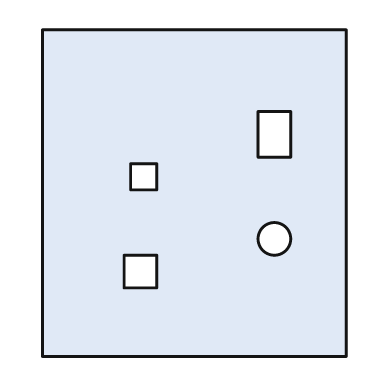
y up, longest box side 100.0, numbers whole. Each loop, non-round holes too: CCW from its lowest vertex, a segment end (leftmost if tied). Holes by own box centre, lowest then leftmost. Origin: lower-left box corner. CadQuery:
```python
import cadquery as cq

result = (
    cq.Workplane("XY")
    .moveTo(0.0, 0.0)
    .lineTo(93.0, 0.0)
    .lineTo(93.0, 100.0)
    .lineTo(0.0, 100.0)
    .close()
    .moveTo(25.0, 21.0)
    .lineTo(35.0, 21.0)
    .lineTo(35.0, 31.0)
    .lineTo(25.0, 31.0)
    .close()
    .moveTo(71.0, 36.0)
    .circle(5.0)
    .moveTo(27.0, 51.0)
    .lineTo(35.0, 51.0)
    .lineTo(35.0, 59.0)
    .lineTo(27.0, 59.0)
    .close()
    .moveTo(66.0, 61.0)
    .lineTo(76.0, 61.0)
    .lineTo(76.0, 75.0)
    .lineTo(66.0, 75.0)
    .close()
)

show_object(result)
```